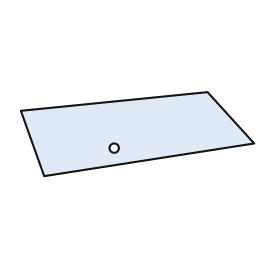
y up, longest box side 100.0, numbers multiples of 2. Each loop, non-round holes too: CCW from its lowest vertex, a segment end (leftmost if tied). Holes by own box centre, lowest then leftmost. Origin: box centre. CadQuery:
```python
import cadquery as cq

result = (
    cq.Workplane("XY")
    .moveTo(-40.0, -18.0)
    .lineTo(50.0, -4.0)
    .lineTo(30.0, 18.0)
    .lineTo(-50.0, 10.0)
    .close()
    .moveTo(-10.0, -6.0)
    .circle(2.0)
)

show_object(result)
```